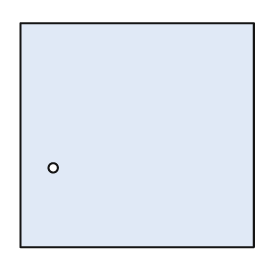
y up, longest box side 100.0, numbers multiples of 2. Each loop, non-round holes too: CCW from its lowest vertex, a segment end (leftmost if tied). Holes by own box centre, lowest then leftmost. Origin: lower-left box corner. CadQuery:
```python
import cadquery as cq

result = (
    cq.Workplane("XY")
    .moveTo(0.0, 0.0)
    .lineTo(100.0, 0.0)
    .lineTo(100.0, 96.0)
    .lineTo(0.0, 96.0)
    .close()
    .moveTo(14.0, 34.0)
    .circle(2.0)
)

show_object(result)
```